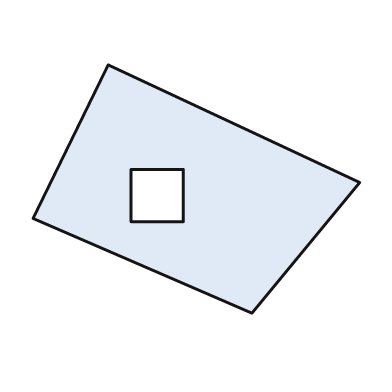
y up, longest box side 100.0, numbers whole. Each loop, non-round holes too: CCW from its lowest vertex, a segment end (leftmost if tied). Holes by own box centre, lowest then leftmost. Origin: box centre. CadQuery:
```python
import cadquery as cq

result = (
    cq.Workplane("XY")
    .moveTo(17.0, -38.0)
    .lineTo(50.0, 2.0)
    .lineTo(-27.0, 38.0)
    .lineTo(-50.0, -9.0)
    .close()
    .moveTo(-20.0, -10.0)
    .lineTo(-4.0, -10.0)
    .lineTo(-4.0, 6.0)
    .lineTo(-20.0, 6.0)
    .close()
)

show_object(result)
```